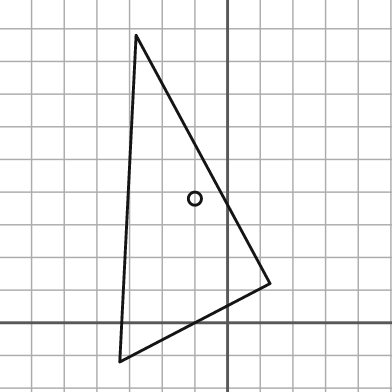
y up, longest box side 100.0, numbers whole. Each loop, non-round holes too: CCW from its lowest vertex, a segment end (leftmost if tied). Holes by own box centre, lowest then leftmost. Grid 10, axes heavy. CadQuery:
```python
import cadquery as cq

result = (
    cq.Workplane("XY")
    .moveTo(-33.0, -12.0)
    .lineTo(13.0, 12.0)
    .lineTo(-28.0, 88.0)
    .close()
    .moveTo(-10.0, 38.0)
    .circle(2.0)
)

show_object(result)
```